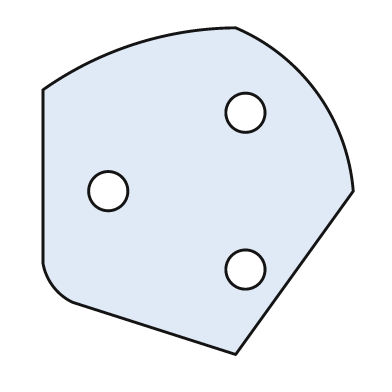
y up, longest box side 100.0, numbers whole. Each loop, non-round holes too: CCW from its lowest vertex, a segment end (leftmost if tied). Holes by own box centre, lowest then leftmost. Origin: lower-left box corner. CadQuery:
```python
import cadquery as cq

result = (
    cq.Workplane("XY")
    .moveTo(59.0, 0.0)
    .lineTo(95.0, 50.0)
    .threePointArc((84.0, 80.0), (59.0, 100.0))
    .threePointArc((28.0, 95.0), (0.0, 81.0))
    .lineTo(0.0, 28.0)
    .threePointArc((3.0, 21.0), (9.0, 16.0))
    .close()
    .moveTo(62.0, 26.0)
    .circle(6.0)
    .moveTo(20.0, 50.0)
    .circle(6.0)
    .moveTo(62.0, 74.0)
    .circle(6.0)
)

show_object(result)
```